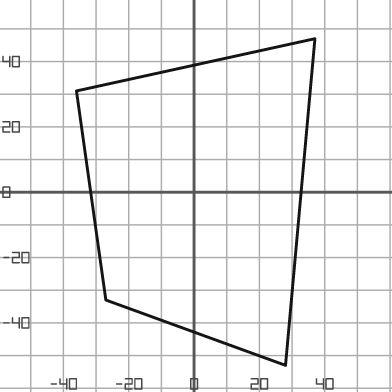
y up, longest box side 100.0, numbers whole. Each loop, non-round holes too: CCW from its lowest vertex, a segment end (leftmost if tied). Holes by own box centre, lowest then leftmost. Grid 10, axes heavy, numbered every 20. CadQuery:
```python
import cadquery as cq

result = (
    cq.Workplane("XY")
    .moveTo(28.0, -53.0)
    .lineTo(37.0, 47.0)
    .lineTo(-36.0, 31.0)
    .lineTo(-27.0, -33.0)
    .close()
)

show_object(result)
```